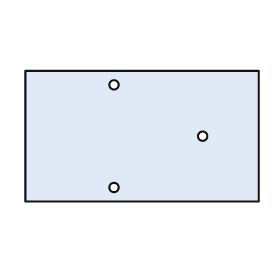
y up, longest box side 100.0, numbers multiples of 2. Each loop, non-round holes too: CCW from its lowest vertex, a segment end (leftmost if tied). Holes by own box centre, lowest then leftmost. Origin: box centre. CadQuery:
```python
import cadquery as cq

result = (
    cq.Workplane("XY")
    .moveTo(-50.0, -28.0)
    .lineTo(50.0, -28.0)
    .lineTo(50.0, 28.0)
    .lineTo(-50.0, 28.0)
    .close()
    .moveTo(-12.0, -22.0)
    .circle(2.0)
    .moveTo(26.0, 0.0)
    .circle(2.0)
    .moveTo(-12.0, 22.0)
    .circle(2.0)
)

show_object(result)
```